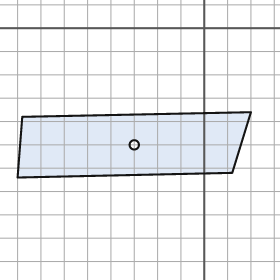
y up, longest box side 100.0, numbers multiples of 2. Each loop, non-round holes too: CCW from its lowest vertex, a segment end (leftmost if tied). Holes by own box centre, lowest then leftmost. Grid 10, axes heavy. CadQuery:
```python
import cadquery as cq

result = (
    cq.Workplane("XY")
    .moveTo(-80.0, -64.0)
    .lineTo(12.0, -62.0)
    .lineTo(20.0, -36.0)
    .lineTo(-78.0, -38.0)
    .close()
    .moveTo(-30.0, -50.0)
    .circle(2.0)
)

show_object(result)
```